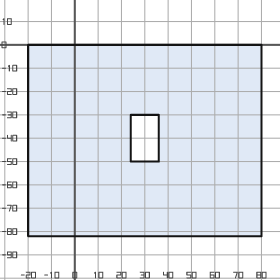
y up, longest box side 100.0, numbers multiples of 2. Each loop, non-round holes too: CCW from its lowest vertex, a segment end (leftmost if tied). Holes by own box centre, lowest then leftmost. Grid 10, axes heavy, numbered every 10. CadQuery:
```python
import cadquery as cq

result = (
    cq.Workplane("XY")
    .moveTo(-20.0, -82.0)
    .lineTo(80.0, -82.0)
    .lineTo(80.0, 0.0)
    .lineTo(-20.0, 0.0)
    .close()
    .moveTo(24.0, -50.0)
    .lineTo(36.0, -50.0)
    .lineTo(36.0, -30.0)
    .lineTo(24.0, -30.0)
    .close()
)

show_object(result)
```